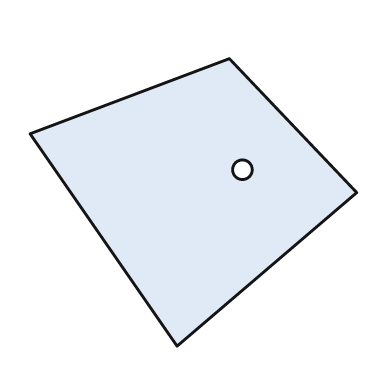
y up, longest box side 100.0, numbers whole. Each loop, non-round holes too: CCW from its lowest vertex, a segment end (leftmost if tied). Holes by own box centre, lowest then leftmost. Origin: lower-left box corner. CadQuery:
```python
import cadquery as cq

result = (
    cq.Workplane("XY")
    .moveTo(45.0, 0.0)
    .lineTo(100.0, 47.0)
    .lineTo(61.0, 88.0)
    .lineTo(0.0, 65.0)
    .close()
    .moveTo(65.0, 54.0)
    .circle(3.0)
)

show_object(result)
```